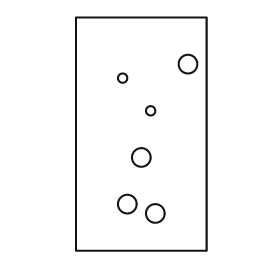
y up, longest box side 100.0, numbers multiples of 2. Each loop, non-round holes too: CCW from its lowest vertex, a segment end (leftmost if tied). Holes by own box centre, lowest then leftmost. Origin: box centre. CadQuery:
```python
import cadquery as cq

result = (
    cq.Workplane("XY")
    .moveTo(-28.0, -50.0)
    .lineTo(28.0, -50.0)
    .lineTo(28.0, 50.0)
    .lineTo(-28.0, 50.0)
    .close()
    .moveTo(6.0, -34.0)
    .circle(4.0)
    .moveTo(-6.0, -30.0)
    .circle(4.0)
    .moveTo(0.0, -10.0)
    .circle(4.0)
    .moveTo(4.0, 10.0)
    .circle(2.0)
    .moveTo(-8.0, 24.0)
    .circle(2.0)
    .moveTo(20.0, 30.0)
    .circle(4.0)
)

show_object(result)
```